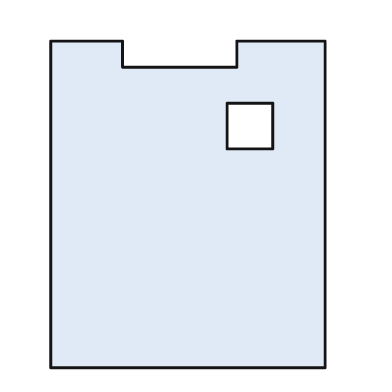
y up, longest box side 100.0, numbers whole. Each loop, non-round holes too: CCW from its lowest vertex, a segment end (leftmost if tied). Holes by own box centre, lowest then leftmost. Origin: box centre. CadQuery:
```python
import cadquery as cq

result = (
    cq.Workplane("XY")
    .moveTo(-42.0, -50.0)
    .lineTo(42.0, -50.0)
    .lineTo(42.0, 50.0)
    .lineTo(15.0, 50.0)
    .lineTo(15.0, 42.0)
    .lineTo(-20.0, 42.0)
    .lineTo(-20.0, 50.0)
    .lineTo(-42.0, 50.0)
    .close()
    .moveTo(12.0, 17.0)
    .lineTo(26.0, 17.0)
    .lineTo(26.0, 31.0)
    .lineTo(12.0, 31.0)
    .close()
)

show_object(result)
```